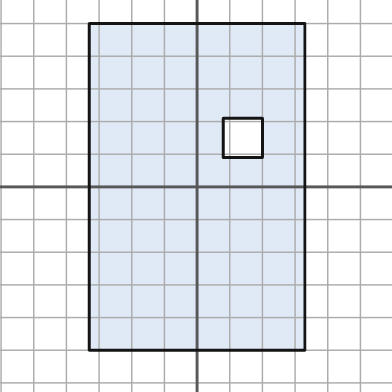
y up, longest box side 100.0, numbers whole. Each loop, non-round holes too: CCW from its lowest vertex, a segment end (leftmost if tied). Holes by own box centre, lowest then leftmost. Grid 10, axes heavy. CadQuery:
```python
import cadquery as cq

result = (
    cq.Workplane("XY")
    .moveTo(-33.0, -50.0)
    .lineTo(33.0, -50.0)
    .lineTo(33.0, 50.0)
    .lineTo(-33.0, 50.0)
    .close()
    .moveTo(8.0, 9.0)
    .lineTo(20.0, 9.0)
    .lineTo(20.0, 21.0)
    .lineTo(8.0, 21.0)
    .close()
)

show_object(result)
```